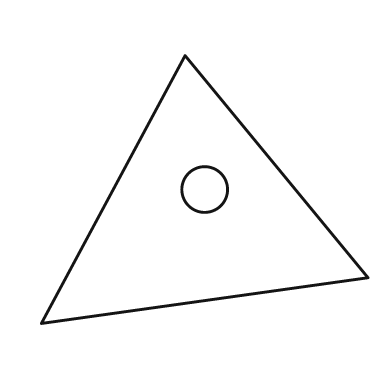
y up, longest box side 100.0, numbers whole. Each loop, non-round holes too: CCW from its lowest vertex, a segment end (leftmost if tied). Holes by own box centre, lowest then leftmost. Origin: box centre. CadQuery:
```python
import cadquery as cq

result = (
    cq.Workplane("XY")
    .moveTo(-50.0, -41.0)
    .lineTo(50.0, -27.0)
    .lineTo(-6.0, 41.0)
    .close()
    .moveTo(0.0, 0.0)
    .circle(7.0)
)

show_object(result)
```